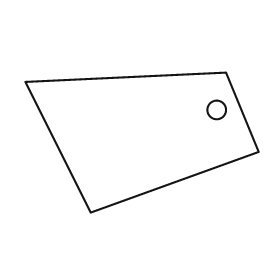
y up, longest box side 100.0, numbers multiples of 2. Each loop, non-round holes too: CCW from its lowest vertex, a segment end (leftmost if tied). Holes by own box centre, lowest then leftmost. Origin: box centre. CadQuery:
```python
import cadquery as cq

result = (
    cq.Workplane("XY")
    .moveTo(-22.0, -30.0)
    .lineTo(50.0, -4.0)
    .lineTo(36.0, 30.0)
    .lineTo(-50.0, 26.0)
    .close()
    .moveTo(32.0, 14.0)
    .circle(4.0)
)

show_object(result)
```